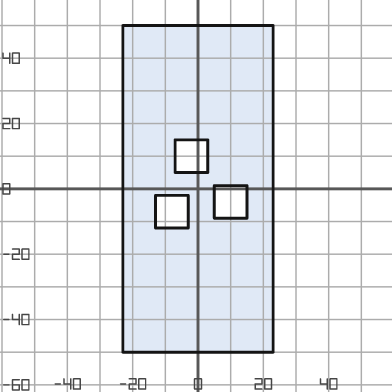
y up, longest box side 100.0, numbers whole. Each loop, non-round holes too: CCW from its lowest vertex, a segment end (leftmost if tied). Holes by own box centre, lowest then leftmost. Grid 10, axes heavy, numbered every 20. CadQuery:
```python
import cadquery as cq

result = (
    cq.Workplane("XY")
    .moveTo(-23.0, -50.0)
    .lineTo(23.0, -50.0)
    .lineTo(23.0, 50.0)
    .lineTo(-23.0, 50.0)
    .close()
    .moveTo(-13.0, -12.0)
    .lineTo(-3.0, -12.0)
    .lineTo(-3.0, -2.0)
    .lineTo(-13.0, -2.0)
    .close()
    .moveTo(5.0, -9.0)
    .lineTo(15.0, -9.0)
    .lineTo(15.0, 1.0)
    .lineTo(5.0, 1.0)
    .close()
    .moveTo(-7.0, 5.0)
    .lineTo(3.0, 5.0)
    .lineTo(3.0, 15.0)
    .lineTo(-7.0, 15.0)
    .close()
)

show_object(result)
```